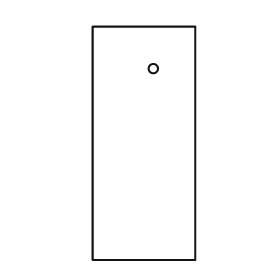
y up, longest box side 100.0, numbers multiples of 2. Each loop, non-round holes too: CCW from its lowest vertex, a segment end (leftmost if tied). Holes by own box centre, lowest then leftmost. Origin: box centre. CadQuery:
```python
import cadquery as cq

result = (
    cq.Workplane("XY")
    .moveTo(-22.0, -50.0)
    .lineTo(22.0, -50.0)
    .lineTo(22.0, 50.0)
    .lineTo(-22.0, 50.0)
    .close()
    .moveTo(4.0, 32.0)
    .circle(2.0)
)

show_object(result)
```